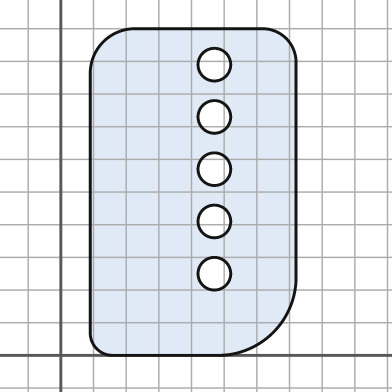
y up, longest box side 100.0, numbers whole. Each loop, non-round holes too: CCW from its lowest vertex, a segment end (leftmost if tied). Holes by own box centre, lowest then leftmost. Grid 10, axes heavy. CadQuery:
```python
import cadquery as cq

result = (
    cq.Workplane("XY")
    .moveTo(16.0, 0.0)
    .lineTo(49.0, 0.0)
    .threePointArc((65.0, 7.0), (72.0, 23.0))
    .lineTo(72.0, 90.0)
    .threePointArc((69.0, 97.0), (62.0, 100.0))
    .lineTo(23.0, 100.0)
    .threePointArc((13.0, 96.0), (9.0, 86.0))
    .lineTo(9.0, 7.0)
    .threePointArc((11.0, 2.0), (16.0, 0.0))
    .close()
    .moveTo(47.0, 25.0)
    .circle(5.0)
    .moveTo(47.0, 41.0)
    .circle(5.0)
    .moveTo(47.0, 57.0)
    .circle(5.0)
    .moveTo(47.0, 73.0)
    .circle(5.0)
    .moveTo(47.0, 89.0)
    .circle(5.0)
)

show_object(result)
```